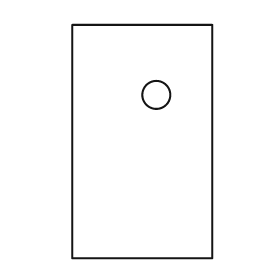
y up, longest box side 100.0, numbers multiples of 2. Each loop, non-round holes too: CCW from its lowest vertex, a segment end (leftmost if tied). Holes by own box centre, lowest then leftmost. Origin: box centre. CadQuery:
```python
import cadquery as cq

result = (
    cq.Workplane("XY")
    .moveTo(-30.0, -50.0)
    .lineTo(30.0, -50.0)
    .lineTo(30.0, 50.0)
    .lineTo(-30.0, 50.0)
    .close()
    .moveTo(6.0, 20.0)
    .circle(6.0)
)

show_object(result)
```